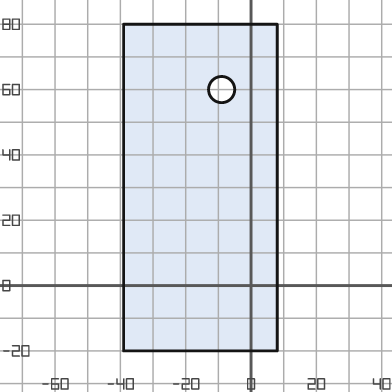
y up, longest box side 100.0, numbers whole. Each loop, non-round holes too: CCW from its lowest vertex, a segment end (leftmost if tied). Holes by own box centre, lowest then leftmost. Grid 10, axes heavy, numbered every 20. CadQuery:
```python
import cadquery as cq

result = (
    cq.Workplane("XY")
    .moveTo(-39.0, -20.0)
    .lineTo(8.0, -20.0)
    .lineTo(8.0, 80.0)
    .lineTo(-39.0, 80.0)
    .close()
    .moveTo(-9.0, 60.0)
    .circle(4.0)
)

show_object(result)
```